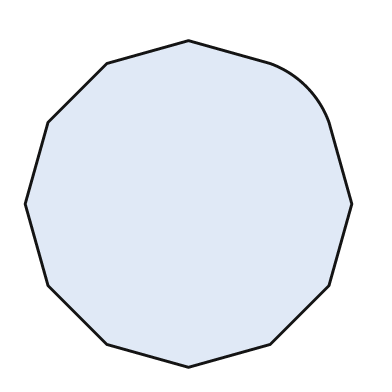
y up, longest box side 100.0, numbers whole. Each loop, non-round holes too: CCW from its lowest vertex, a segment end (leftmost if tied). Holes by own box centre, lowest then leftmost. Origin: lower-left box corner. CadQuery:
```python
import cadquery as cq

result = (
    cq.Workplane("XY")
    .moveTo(50.0, 0.0)
    .lineTo(75.0, 7.0)
    .lineTo(93.0, 25.0)
    .lineTo(100.0, 50.0)
    .lineTo(93.0, 75.0)
    .threePointArc((86.0, 86.0), (75.0, 93.0))
    .lineTo(50.0, 100.0)
    .lineTo(25.0, 93.0)
    .lineTo(7.0, 75.0)
    .lineTo(0.0, 50.0)
    .lineTo(7.0, 25.0)
    .lineTo(25.0, 7.0)
    .close()
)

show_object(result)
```